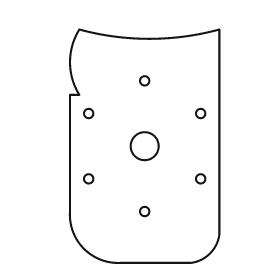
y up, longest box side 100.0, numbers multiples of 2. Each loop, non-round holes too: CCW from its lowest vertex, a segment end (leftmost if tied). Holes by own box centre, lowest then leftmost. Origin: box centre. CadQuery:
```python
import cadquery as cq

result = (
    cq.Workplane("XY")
    .moveTo(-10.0, -50.0)
    .lineTo(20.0, -50.0)
    .threePointArc((28.0, -46.0), (32.0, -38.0))
    .lineTo(32.0, 50.0)
    .threePointArc((2.0, 46.0), (-28.0, 50.0))
    .threePointArc((-32.0, 36.0), (-28.0, 22.0))
    .lineTo(-32.0, 22.0)
    .lineTo(-32.0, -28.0)
    .threePointArc((-26.0, -44.0), (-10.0, -50.0))
    .close()
    .moveTo(0.0, -28.0)
    .circle(2.0)
    .moveTo(-24.0, -14.0)
    .circle(2.0)
    .moveTo(24.0, -14.0)
    .circle(2.0)
    .moveTo(0.0, 0.0)
    .circle(6.0)
    .moveTo(-24.0, 14.0)
    .circle(2.0)
    .moveTo(24.0, 14.0)
    .circle(2.0)
    .moveTo(0.0, 28.0)
    .circle(2.0)
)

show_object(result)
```